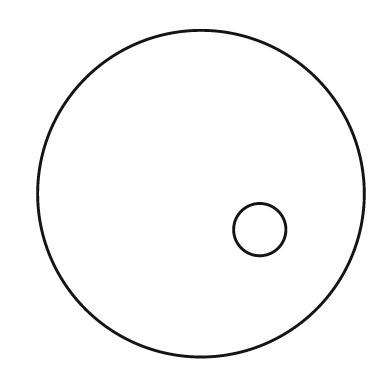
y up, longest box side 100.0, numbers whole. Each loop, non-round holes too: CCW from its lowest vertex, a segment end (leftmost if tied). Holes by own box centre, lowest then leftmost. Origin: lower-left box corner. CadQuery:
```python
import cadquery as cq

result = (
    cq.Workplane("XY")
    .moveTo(50.0, 50.0)
    .circle(50.0)
    .moveTo(68.0, 39.0)
    .circle(8.0)
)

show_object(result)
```